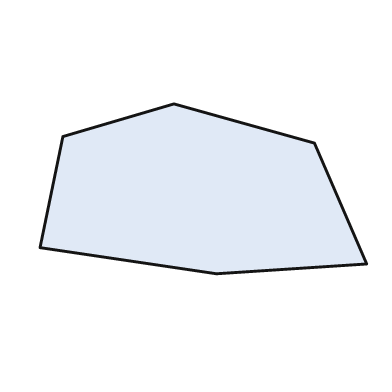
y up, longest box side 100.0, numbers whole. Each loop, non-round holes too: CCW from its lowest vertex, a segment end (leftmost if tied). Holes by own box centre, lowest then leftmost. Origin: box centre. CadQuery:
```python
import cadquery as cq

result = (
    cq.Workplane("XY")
    .moveTo(4.0, -26.0)
    .lineTo(50.0, -23.0)
    .lineTo(34.0, 14.0)
    .lineTo(-9.0, 26.0)
    .lineTo(-43.0, 16.0)
    .lineTo(-50.0, -18.0)
    .close()
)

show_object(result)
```